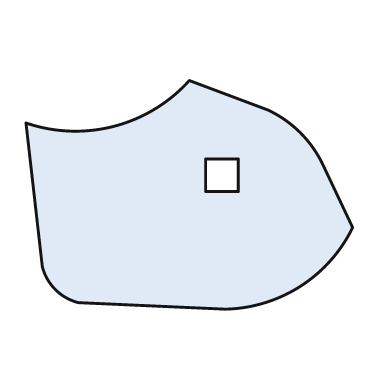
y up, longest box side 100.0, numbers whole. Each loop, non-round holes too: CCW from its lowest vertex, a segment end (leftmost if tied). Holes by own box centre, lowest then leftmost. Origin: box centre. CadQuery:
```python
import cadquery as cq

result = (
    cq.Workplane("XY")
    .moveTo(11.0, -35.0)
    .threePointArc((34.0, -28.0), (50.0, -10.0))
    .lineTo(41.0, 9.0)
    .threePointArc((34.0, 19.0), (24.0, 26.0))
    .lineTo(0.0, 35.0)
    .threePointArc((-23.0, 21.0), (-50.0, 22.0))
    .lineTo(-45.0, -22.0)
    .threePointArc((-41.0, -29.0), (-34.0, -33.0))
    .close()
    .moveTo(5.0, 1.0)
    .lineTo(15.0, 1.0)
    .lineTo(15.0, 11.0)
    .lineTo(5.0, 11.0)
    .close()
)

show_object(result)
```